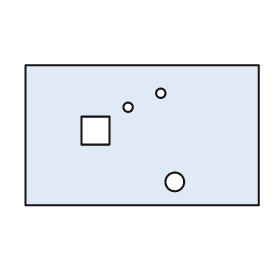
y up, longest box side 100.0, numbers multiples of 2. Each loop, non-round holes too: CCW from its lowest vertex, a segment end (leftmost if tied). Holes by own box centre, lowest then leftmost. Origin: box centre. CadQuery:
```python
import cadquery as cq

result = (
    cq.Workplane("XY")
    .moveTo(-50.0, -30.0)
    .lineTo(50.0, -30.0)
    .lineTo(50.0, 30.0)
    .lineTo(-50.0, 30.0)
    .close()
    .moveTo(14.0, -20.0)
    .circle(4.0)
    .moveTo(-26.0, -4.0)
    .lineTo(-14.0, -4.0)
    .lineTo(-14.0, 8.0)
    .lineTo(-26.0, 8.0)
    .close()
    .moveTo(-6.0, 12.0)
    .circle(2.0)
    .moveTo(8.0, 18.0)
    .circle(2.0)
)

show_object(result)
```